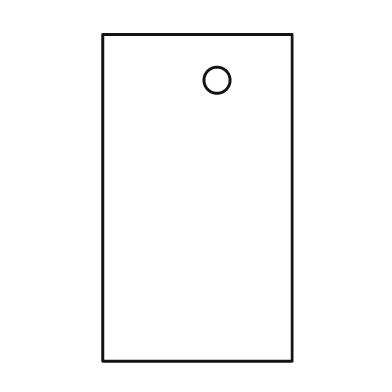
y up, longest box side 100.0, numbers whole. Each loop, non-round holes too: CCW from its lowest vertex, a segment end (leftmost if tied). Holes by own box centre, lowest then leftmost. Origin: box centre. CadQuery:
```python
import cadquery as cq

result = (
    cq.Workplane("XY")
    .moveTo(-29.0, -50.0)
    .lineTo(29.0, -50.0)
    .lineTo(29.0, 50.0)
    .lineTo(-29.0, 50.0)
    .close()
    .moveTo(6.0, 36.0)
    .circle(4.0)
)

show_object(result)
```